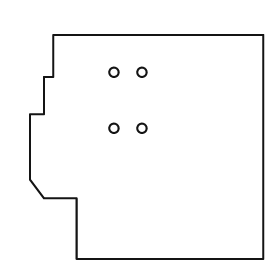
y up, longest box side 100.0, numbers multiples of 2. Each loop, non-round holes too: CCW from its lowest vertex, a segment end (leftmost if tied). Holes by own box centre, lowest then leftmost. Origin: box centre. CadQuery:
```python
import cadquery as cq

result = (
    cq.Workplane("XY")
    .moveTo(-30.0, -48.0)
    .lineTo(50.0, -48.0)
    .lineTo(50.0, 48.0)
    .lineTo(-40.0, 48.0)
    .lineTo(-40.0, 30.0)
    .lineTo(-44.0, 30.0)
    .lineTo(-44.0, 14.0)
    .lineTo(-50.0, 14.0)
    .lineTo(-50.0, -14.0)
    .lineTo(-44.0, -22.0)
    .lineTo(-30.0, -22.0)
    .close()
    .moveTo(-14.0, 8.0)
    .circle(2.0)
    .moveTo(-2.0, 8.0)
    .circle(2.0)
    .moveTo(-14.0, 32.0)
    .circle(2.0)
    .moveTo(-2.0, 32.0)
    .circle(2.0)
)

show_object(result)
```